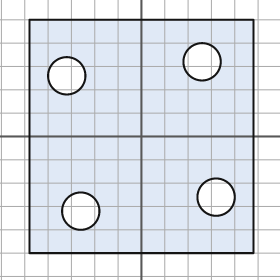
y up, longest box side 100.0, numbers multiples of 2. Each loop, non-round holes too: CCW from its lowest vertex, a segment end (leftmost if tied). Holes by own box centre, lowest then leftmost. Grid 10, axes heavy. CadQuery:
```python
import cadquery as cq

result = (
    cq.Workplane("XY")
    .moveTo(-48.0, -50.0)
    .lineTo(48.0, -50.0)
    .lineTo(48.0, 50.0)
    .lineTo(-48.0, 50.0)
    .close()
    .moveTo(-26.0, -32.0)
    .circle(8.0)
    .moveTo(32.0, -26.0)
    .circle(8.0)
    .moveTo(-32.0, 26.0)
    .circle(8.0)
    .moveTo(26.0, 32.0)
    .circle(8.0)
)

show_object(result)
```